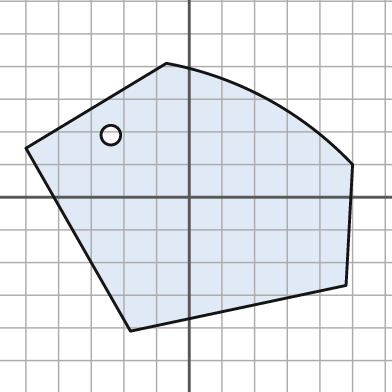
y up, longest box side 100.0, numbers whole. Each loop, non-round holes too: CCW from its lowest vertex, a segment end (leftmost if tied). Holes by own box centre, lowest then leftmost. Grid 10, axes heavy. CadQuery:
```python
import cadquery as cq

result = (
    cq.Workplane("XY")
    .moveTo(-18.0, -41.0)
    .lineTo(48.0, -27.0)
    .lineTo(50.0, 10.0)
    .threePointArc((24.0, 30.0), (-7.0, 41.0))
    .lineTo(-50.0, 15.0)
    .close()
    .moveTo(-24.0, 19.0)
    .circle(3.0)
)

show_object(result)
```